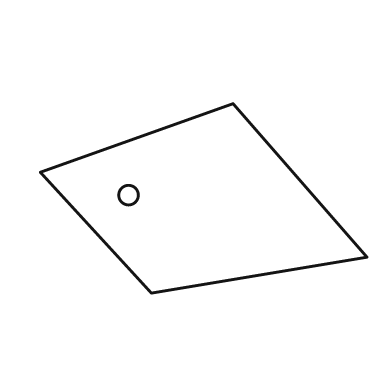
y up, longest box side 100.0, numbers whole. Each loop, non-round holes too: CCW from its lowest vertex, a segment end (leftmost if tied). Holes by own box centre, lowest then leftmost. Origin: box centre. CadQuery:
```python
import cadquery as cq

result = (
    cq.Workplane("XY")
    .moveTo(-16.0, -29.0)
    .lineTo(50.0, -18.0)
    .lineTo(9.0, 29.0)
    .lineTo(-50.0, 8.0)
    .close()
    .moveTo(-23.0, 1.0)
    .circle(3.0)
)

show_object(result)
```